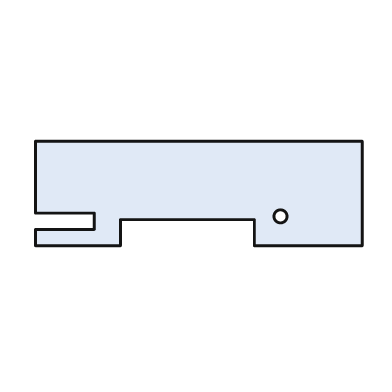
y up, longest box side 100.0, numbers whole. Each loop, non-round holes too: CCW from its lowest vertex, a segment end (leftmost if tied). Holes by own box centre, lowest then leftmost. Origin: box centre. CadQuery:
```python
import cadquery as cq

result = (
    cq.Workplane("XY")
    .moveTo(-50.0, -16.0)
    .lineTo(-24.0, -16.0)
    .lineTo(-24.0, -8.0)
    .lineTo(17.0, -8.0)
    .lineTo(17.0, -16.0)
    .lineTo(50.0, -16.0)
    .lineTo(50.0, 16.0)
    .lineTo(-50.0, 16.0)
    .lineTo(-50.0, -6.0)
    .lineTo(-32.0, -6.0)
    .lineTo(-32.0, -11.0)
    .lineTo(-50.0, -11.0)
    .close()
    .moveTo(25.0, -7.0)
    .circle(2.0)
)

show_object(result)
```